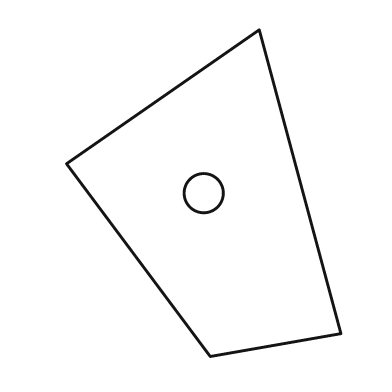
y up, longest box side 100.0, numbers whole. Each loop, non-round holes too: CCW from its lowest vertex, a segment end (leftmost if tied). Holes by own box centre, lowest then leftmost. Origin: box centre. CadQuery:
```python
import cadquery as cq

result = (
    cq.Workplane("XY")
    .moveTo(2.0, -50.0)
    .lineTo(42.0, -43.0)
    .lineTo(17.0, 50.0)
    .lineTo(-42.0, 9.0)
    .close()
    .moveTo(0.0, 0.0)
    .circle(6.0)
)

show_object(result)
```